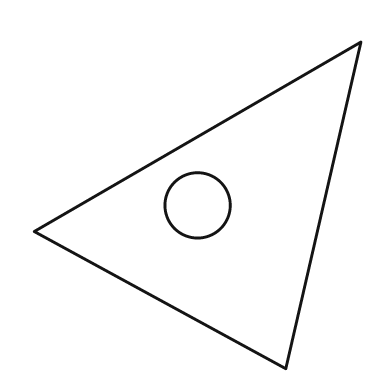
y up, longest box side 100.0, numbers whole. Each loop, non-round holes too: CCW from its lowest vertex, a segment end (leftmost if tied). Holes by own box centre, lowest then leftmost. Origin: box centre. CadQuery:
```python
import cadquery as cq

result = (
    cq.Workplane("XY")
    .moveTo(27.0, -50.0)
    .lineTo(50.0, 50.0)
    .lineTo(-50.0, -8.0)
    .close()
    .moveTo(0.0, 0.0)
    .circle(10.0)
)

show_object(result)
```